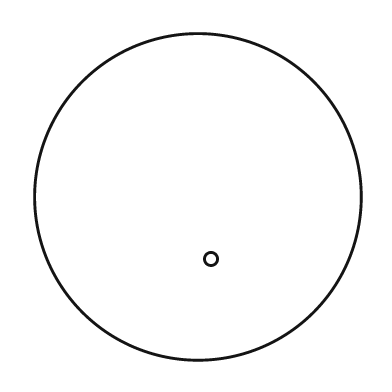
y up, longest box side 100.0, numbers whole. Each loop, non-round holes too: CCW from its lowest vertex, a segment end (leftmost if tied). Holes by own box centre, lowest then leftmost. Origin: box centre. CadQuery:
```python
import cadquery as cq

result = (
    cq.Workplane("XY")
    .moveTo(0.0, 0.0)
    .circle(50.0)
    .moveTo(4.0, -19.0)
    .circle(2.0)
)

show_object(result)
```